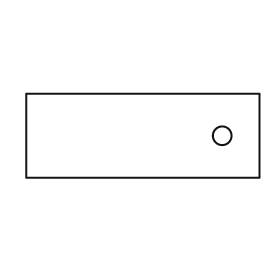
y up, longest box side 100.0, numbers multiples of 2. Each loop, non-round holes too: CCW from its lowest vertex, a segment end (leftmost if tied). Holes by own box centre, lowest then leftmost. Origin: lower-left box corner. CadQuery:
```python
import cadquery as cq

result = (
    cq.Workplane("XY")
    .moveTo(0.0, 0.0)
    .lineTo(100.0, 0.0)
    .lineTo(100.0, 36.0)
    .lineTo(0.0, 36.0)
    .close()
    .moveTo(84.0, 18.0)
    .circle(4.0)
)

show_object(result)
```